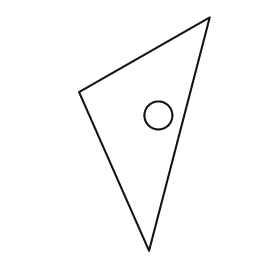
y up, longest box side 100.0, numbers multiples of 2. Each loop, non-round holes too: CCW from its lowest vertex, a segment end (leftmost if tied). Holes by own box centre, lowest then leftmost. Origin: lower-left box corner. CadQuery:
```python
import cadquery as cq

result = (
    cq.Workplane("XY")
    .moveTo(30.0, 0.0)
    .lineTo(56.0, 100.0)
    .lineTo(0.0, 68.0)
    .close()
    .moveTo(34.0, 58.0)
    .circle(6.0)
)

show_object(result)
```